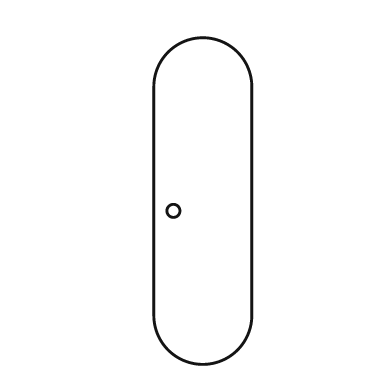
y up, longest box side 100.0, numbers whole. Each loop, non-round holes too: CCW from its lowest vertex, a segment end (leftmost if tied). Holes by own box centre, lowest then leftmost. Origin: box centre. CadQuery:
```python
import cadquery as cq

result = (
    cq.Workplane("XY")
    .moveTo(-15.0, -35.0)
    .threePointArc((0.0, -50.0), (15.0, -35.0))
    .lineTo(15.0, 35.0)
    .threePointArc((0.0, 50.0), (-15.0, 35.0))
    .close()
    .moveTo(-9.0, -3.0)
    .circle(2.0)
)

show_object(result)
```